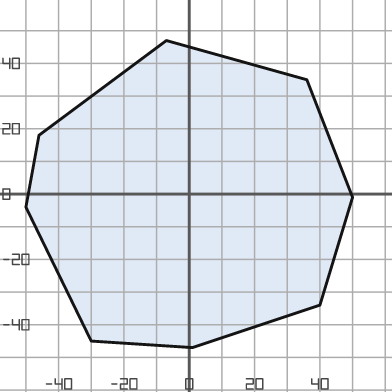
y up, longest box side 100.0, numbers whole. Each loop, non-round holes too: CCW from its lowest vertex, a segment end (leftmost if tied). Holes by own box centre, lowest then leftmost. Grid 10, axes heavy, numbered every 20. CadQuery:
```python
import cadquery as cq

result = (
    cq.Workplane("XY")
    .moveTo(1.0, -47.0)
    .lineTo(40.0, -34.0)
    .lineTo(50.0, -1.0)
    .lineTo(36.0, 35.0)
    .lineTo(-7.0, 47.0)
    .lineTo(-46.0, 18.0)
    .lineTo(-50.0, -4.0)
    .lineTo(-30.0, -45.0)
    .close()
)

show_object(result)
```